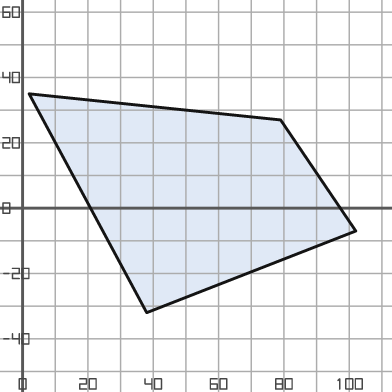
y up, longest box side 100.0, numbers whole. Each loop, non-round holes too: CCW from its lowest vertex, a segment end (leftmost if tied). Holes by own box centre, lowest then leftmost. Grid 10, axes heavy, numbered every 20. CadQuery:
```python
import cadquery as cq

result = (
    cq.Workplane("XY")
    .moveTo(38.0, -32.0)
    .lineTo(102.0, -7.0)
    .lineTo(79.0, 27.0)
    .lineTo(2.0, 35.0)
    .close()
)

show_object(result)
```